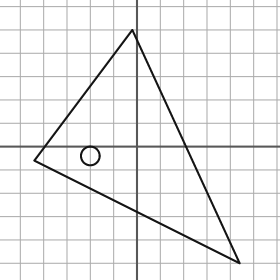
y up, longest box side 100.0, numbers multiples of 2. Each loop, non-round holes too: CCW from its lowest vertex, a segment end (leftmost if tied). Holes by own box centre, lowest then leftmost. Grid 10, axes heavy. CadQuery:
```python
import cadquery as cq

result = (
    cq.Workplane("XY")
    .moveTo(44.0, -50.0)
    .lineTo(-2.0, 50.0)
    .lineTo(-44.0, -6.0)
    .close()
    .moveTo(-20.0, -4.0)
    .circle(4.0)
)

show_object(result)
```